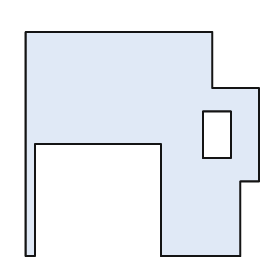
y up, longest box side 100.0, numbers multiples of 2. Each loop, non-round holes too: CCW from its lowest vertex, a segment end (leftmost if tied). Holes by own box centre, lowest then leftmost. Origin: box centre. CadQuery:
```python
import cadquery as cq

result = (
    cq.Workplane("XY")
    .moveTo(-50.0, -48.0)
    .lineTo(-46.0, -48.0)
    .lineTo(-46.0, 0.0)
    .lineTo(8.0, 0.0)
    .lineTo(8.0, -48.0)
    .lineTo(42.0, -48.0)
    .lineTo(42.0, -16.0)
    .lineTo(50.0, -16.0)
    .lineTo(50.0, 24.0)
    .lineTo(30.0, 24.0)
    .lineTo(30.0, 48.0)
    .lineTo(-50.0, 48.0)
    .close()
    .moveTo(26.0, -6.0)
    .lineTo(38.0, -6.0)
    .lineTo(38.0, 14.0)
    .lineTo(26.0, 14.0)
    .close()
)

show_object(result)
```